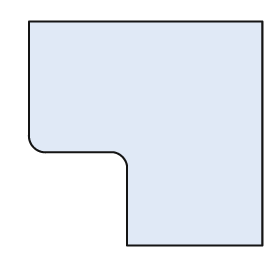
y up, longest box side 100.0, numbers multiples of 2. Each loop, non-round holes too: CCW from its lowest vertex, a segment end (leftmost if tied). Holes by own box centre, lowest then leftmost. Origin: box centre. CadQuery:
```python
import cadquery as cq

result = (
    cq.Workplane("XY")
    .moveTo(-8.0, -48.0)
    .lineTo(50.0, -48.0)
    .lineTo(50.0, 48.0)
    .lineTo(-50.0, 48.0)
    .lineTo(-50.0, 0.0)
    .threePointArc((-48.0, -6.0), (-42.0, -8.0))
    .lineTo(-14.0, -8.0)
    .threePointArc((-10.0, -10.0), (-8.0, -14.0))
    .close()
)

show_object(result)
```